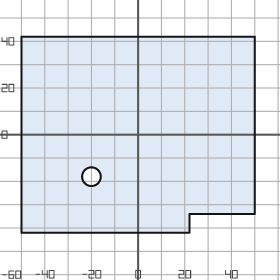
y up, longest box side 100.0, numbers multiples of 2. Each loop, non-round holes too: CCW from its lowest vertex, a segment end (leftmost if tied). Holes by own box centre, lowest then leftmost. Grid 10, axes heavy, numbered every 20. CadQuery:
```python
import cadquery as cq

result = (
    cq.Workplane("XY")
    .moveTo(-50.0, -42.0)
    .lineTo(22.0, -42.0)
    .lineTo(22.0, -34.0)
    .lineTo(50.0, -34.0)
    .lineTo(50.0, 42.0)
    .lineTo(-50.0, 42.0)
    .close()
    .moveTo(-20.0, -18.0)
    .circle(4.0)
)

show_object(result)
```